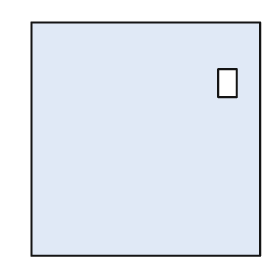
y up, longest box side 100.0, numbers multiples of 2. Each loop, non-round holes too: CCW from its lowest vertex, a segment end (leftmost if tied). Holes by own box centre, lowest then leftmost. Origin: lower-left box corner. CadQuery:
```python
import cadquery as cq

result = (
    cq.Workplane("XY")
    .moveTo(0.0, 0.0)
    .lineTo(98.0, 0.0)
    .lineTo(98.0, 100.0)
    .lineTo(0.0, 100.0)
    .close()
    .moveTo(80.0, 68.0)
    .lineTo(88.0, 68.0)
    .lineTo(88.0, 80.0)
    .lineTo(80.0, 80.0)
    .close()
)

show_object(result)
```